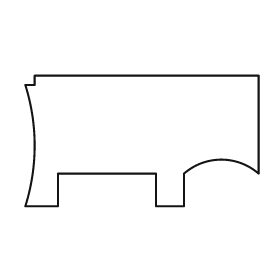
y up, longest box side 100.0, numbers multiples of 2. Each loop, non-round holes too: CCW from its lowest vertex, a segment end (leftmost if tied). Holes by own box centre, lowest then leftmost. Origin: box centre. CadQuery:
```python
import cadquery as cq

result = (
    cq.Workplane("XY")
    .moveTo(-50.0, -28.0)
    .lineTo(-36.0, -28.0)
    .lineTo(-36.0, -14.0)
    .lineTo(6.0, -14.0)
    .lineTo(6.0, -28.0)
    .lineTo(18.0, -28.0)
    .lineTo(18.0, -14.0)
    .threePointArc((34.0, -8.0), (50.0, -14.0))
    .lineTo(50.0, 28.0)
    .lineTo(-46.0, 28.0)
    .lineTo(-46.0, 24.0)
    .lineTo(-50.0, 24.0)
    .threePointArc((-46.0, -2.0), (-50.0, -28.0))
    .close()
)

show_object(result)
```